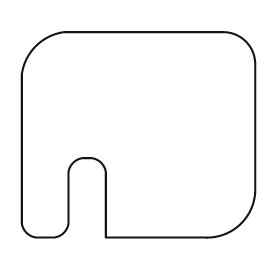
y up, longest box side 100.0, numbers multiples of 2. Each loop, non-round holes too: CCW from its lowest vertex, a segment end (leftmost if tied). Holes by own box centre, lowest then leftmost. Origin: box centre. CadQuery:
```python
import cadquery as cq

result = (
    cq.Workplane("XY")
    .moveTo(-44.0, -44.0)
    .lineTo(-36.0, -44.0)
    .threePointArc((-32.0, -42.0), (-30.0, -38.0))
    .lineTo(-30.0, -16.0)
    .threePointArc((-28.0, -12.0), (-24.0, -10.0))
    .lineTo(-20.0, -10.0)
    .threePointArc((-16.0, -12.0), (-14.0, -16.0))
    .lineTo(-14.0, -44.0)
    .lineTo(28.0, -44.0)
    .threePointArc((44.0, -38.0), (50.0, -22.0))
    .lineTo(50.0, 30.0)
    .threePointArc((46.0, 40.0), (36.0, 44.0))
    .lineTo(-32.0, 44.0)
    .threePointArc((-44.0, 38.0), (-50.0, 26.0))
    .lineTo(-50.0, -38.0)
    .threePointArc((-48.0, -42.0), (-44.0, -44.0))
    .close()
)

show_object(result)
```